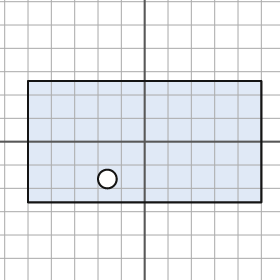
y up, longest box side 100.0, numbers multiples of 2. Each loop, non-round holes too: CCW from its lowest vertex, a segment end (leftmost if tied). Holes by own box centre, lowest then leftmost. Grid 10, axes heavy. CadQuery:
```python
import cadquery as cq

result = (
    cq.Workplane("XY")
    .moveTo(-50.0, -26.0)
    .lineTo(50.0, -26.0)
    .lineTo(50.0, 26.0)
    .lineTo(-50.0, 26.0)
    .close()
    .moveTo(-16.0, -16.0)
    .circle(4.0)
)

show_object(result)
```